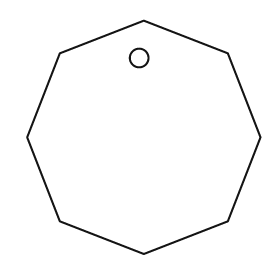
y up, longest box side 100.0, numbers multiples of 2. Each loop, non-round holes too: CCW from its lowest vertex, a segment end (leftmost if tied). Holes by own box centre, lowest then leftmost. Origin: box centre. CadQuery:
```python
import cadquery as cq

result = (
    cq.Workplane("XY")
    .moveTo(0.0, -50.0)
    .lineTo(36.0, -36.0)
    .lineTo(50.0, 0.0)
    .lineTo(36.0, 36.0)
    .lineTo(0.0, 50.0)
    .lineTo(-36.0, 36.0)
    .lineTo(-50.0, 0.0)
    .lineTo(-36.0, -36.0)
    .close()
    .moveTo(-2.0, 34.0)
    .circle(4.0)
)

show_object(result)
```